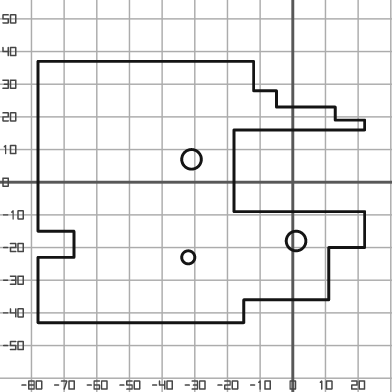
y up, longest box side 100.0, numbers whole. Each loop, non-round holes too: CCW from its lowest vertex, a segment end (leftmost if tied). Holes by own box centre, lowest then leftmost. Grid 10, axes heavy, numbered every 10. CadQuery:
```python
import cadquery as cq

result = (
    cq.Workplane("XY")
    .moveTo(-78.0, -43.0)
    .lineTo(-15.0, -43.0)
    .lineTo(-15.0, -36.0)
    .lineTo(11.0, -36.0)
    .lineTo(11.0, -20.0)
    .lineTo(22.0, -20.0)
    .lineTo(22.0, -9.0)
    .lineTo(-18.0, -9.0)
    .lineTo(-18.0, 16.0)
    .lineTo(22.0, 16.0)
    .lineTo(22.0, 19.0)
    .lineTo(13.0, 19.0)
    .lineTo(13.0, 23.0)
    .lineTo(-5.0, 23.0)
    .lineTo(-5.0, 28.0)
    .lineTo(-12.0, 28.0)
    .lineTo(-12.0, 37.0)
    .lineTo(-78.0, 37.0)
    .lineTo(-78.0, -15.0)
    .lineTo(-67.0, -15.0)
    .lineTo(-67.0, -23.0)
    .lineTo(-78.0, -23.0)
    .close()
    .moveTo(-32.0, -23.0)
    .circle(2.0)
    .moveTo(1.0, -18.0)
    .circle(3.0)
    .moveTo(-31.0, 7.0)
    .circle(3.0)
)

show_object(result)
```